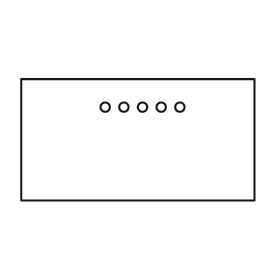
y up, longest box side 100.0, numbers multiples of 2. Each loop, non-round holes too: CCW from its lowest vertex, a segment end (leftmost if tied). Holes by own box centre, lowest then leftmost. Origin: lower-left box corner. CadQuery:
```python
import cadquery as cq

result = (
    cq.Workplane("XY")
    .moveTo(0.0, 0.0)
    .lineTo(100.0, 0.0)
    .lineTo(100.0, 52.0)
    .lineTo(0.0, 52.0)
    .close()
    .moveTo(36.0, 40.0)
    .circle(2.0)
    .moveTo(44.0, 40.0)
    .circle(2.0)
    .moveTo(52.0, 40.0)
    .circle(2.0)
    .moveTo(60.0, 40.0)
    .circle(2.0)
    .moveTo(68.0, 40.0)
    .circle(2.0)
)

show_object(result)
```